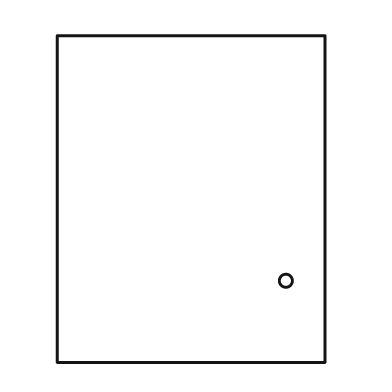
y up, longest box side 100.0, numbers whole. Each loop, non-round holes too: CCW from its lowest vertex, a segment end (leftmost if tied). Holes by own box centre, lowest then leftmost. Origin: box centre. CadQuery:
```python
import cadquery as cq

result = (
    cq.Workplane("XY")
    .moveTo(-41.0, -50.0)
    .lineTo(41.0, -50.0)
    .lineTo(41.0, 50.0)
    .lineTo(-41.0, 50.0)
    .close()
    .moveTo(29.0, -25.0)
    .circle(2.0)
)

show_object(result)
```